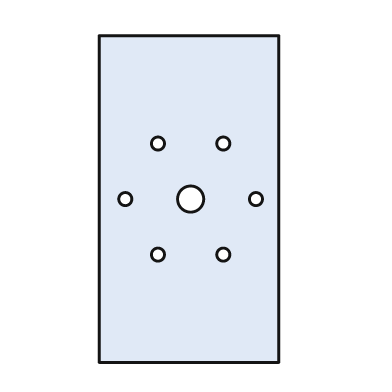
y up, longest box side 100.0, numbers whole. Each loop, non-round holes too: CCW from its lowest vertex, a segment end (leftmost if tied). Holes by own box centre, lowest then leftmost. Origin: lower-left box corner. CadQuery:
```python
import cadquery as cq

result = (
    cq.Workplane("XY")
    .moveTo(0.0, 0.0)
    .lineTo(55.0, 0.0)
    .lineTo(55.0, 100.0)
    .lineTo(0.0, 100.0)
    .close()
    .moveTo(18.0, 33.0)
    .circle(2.0)
    .moveTo(38.0, 33.0)
    .circle(2.0)
    .moveTo(8.0, 50.0)
    .circle(2.0)
    .moveTo(28.0, 50.0)
    .circle(4.0)
    .moveTo(48.0, 50.0)
    .circle(2.0)
    .moveTo(18.0, 67.0)
    .circle(2.0)
    .moveTo(38.0, 67.0)
    .circle(2.0)
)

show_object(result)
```